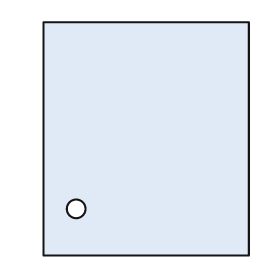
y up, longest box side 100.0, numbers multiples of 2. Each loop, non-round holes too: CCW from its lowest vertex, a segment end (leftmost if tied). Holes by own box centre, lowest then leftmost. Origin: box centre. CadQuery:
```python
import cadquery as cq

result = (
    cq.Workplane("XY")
    .moveTo(-44.0, -50.0)
    .lineTo(44.0, -50.0)
    .lineTo(44.0, 50.0)
    .lineTo(-44.0, 50.0)
    .close()
    .moveTo(-30.0, -30.0)
    .circle(4.0)
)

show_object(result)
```